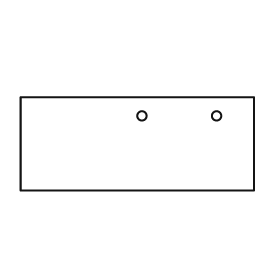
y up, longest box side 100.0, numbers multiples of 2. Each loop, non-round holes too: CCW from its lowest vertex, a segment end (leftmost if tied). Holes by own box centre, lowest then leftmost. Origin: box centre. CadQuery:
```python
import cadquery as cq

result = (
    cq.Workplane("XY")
    .moveTo(-50.0, -20.0)
    .lineTo(50.0, -20.0)
    .lineTo(50.0, 20.0)
    .lineTo(-50.0, 20.0)
    .close()
    .moveTo(2.0, 12.0)
    .circle(2.0)
    .moveTo(34.0, 12.0)
    .circle(2.0)
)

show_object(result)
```